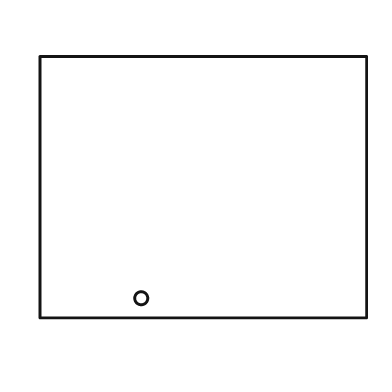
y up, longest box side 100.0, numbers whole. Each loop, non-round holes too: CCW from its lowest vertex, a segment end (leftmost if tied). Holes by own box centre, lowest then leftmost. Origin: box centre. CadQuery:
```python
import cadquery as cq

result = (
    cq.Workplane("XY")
    .moveTo(-50.0, -40.0)
    .lineTo(50.0, -40.0)
    .lineTo(50.0, 40.0)
    .lineTo(-50.0, 40.0)
    .close()
    .moveTo(-19.0, -34.0)
    .circle(2.0)
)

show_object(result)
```